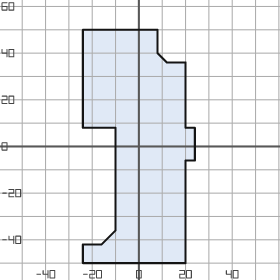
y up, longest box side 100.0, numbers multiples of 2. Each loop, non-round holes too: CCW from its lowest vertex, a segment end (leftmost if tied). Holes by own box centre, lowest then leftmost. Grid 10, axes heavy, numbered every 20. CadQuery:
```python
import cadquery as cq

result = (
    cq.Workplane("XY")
    .moveTo(-24.0, -50.0)
    .lineTo(20.0, -50.0)
    .lineTo(20.0, -6.0)
    .lineTo(24.0, -6.0)
    .lineTo(24.0, 8.0)
    .lineTo(20.0, 8.0)
    .lineTo(20.0, 36.0)
    .lineTo(12.0, 36.0)
    .lineTo(8.0, 40.0)
    .lineTo(8.0, 50.0)
    .lineTo(-24.0, 50.0)
    .lineTo(-24.0, 8.0)
    .lineTo(-10.0, 8.0)
    .lineTo(-10.0, -36.0)
    .lineTo(-16.0, -42.0)
    .lineTo(-24.0, -42.0)
    .close()
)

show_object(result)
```